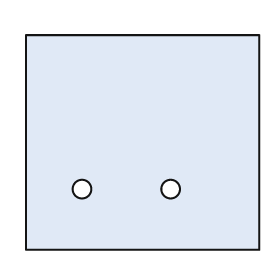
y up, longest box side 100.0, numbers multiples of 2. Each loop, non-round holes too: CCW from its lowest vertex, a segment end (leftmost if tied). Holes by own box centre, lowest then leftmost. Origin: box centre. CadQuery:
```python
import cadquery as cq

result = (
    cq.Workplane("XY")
    .moveTo(-50.0, -46.0)
    .lineTo(50.0, -46.0)
    .lineTo(50.0, 46.0)
    .lineTo(-50.0, 46.0)
    .close()
    .moveTo(-26.0, -20.0)
    .circle(4.0)
    .moveTo(12.0, -20.0)
    .circle(4.0)
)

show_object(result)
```